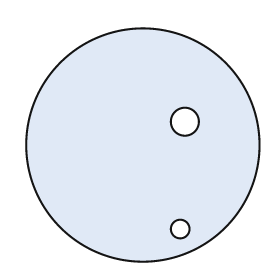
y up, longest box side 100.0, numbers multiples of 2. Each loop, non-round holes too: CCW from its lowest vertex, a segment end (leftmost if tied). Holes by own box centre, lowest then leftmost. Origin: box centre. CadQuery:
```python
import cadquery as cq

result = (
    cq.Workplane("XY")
    .moveTo(0.0, 0.0)
    .circle(50.0)
    .moveTo(16.0, -36.0)
    .circle(4.0)
    .moveTo(18.0, 10.0)
    .circle(6.0)
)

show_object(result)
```